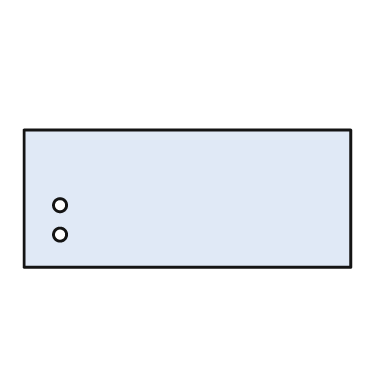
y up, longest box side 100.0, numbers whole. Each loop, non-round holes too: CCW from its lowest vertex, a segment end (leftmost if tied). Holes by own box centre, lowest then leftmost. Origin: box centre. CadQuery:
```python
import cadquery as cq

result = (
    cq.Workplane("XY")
    .moveTo(-50.0, -21.0)
    .lineTo(50.0, -21.0)
    .lineTo(50.0, 21.0)
    .lineTo(-50.0, 21.0)
    .close()
    .moveTo(-39.0, -11.0)
    .circle(2.0)
    .moveTo(-39.0, -2.0)
    .circle(2.0)
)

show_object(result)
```